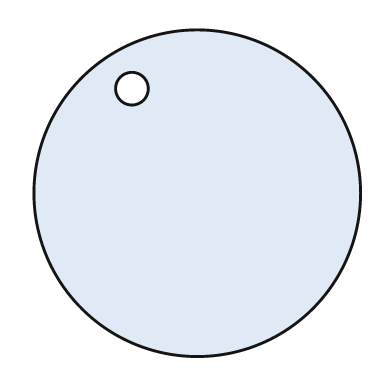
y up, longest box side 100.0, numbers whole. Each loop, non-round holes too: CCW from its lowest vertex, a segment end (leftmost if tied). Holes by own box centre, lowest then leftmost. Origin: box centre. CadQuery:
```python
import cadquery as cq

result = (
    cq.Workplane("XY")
    .moveTo(0.0, 0.0)
    .circle(50.0)
    .moveTo(-20.0, 32.0)
    .circle(5.0)
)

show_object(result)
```